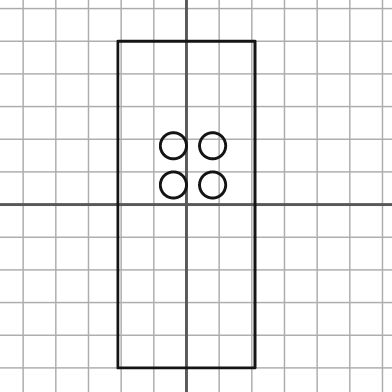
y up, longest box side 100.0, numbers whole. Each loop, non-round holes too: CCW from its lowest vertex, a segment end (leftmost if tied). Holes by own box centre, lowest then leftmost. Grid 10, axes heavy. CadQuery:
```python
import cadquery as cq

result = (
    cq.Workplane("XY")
    .moveTo(-21.0, -50.0)
    .lineTo(21.0, -50.0)
    .lineTo(21.0, 50.0)
    .lineTo(-21.0, 50.0)
    .close()
    .moveTo(-4.0, 6.0)
    .circle(4.0)
    .moveTo(8.0, 6.0)
    .circle(4.0)
    .moveTo(-4.0, 18.0)
    .circle(4.0)
    .moveTo(8.0, 18.0)
    .circle(4.0)
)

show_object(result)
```